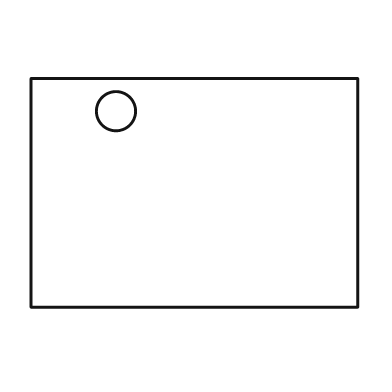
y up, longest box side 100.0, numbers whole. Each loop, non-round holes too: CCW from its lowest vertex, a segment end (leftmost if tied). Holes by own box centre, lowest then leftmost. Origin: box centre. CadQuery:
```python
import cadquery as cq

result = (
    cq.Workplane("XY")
    .moveTo(-50.0, -35.0)
    .lineTo(50.0, -35.0)
    .lineTo(50.0, 35.0)
    .lineTo(-50.0, 35.0)
    .close()
    .moveTo(-24.0, 25.0)
    .circle(6.0)
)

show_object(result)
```